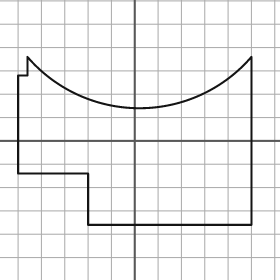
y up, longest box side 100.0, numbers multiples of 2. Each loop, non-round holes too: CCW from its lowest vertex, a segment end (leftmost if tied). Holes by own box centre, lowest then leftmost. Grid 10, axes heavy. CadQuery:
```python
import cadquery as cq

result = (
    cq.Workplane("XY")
    .moveTo(-20.0, -36.0)
    .lineTo(50.0, -36.0)
    .lineTo(50.0, 36.0)
    .threePointArc((2.0, 14.0), (-46.0, 36.0))
    .lineTo(-46.0, 28.0)
    .lineTo(-50.0, 28.0)
    .lineTo(-50.0, -14.0)
    .lineTo(-20.0, -14.0)
    .close()
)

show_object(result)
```